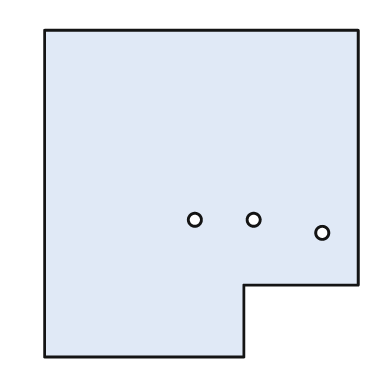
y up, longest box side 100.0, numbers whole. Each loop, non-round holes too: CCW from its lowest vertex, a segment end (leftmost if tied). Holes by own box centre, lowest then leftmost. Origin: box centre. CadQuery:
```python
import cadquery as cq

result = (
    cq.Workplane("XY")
    .moveTo(-48.0, -50.0)
    .lineTo(13.0, -50.0)
    .lineTo(13.0, -28.0)
    .lineTo(48.0, -28.0)
    .lineTo(48.0, 50.0)
    .lineTo(-48.0, 50.0)
    .close()
    .moveTo(37.0, -12.0)
    .circle(2.0)
    .moveTo(-2.0, -8.0)
    .circle(2.0)
    .moveTo(16.0, -8.0)
    .circle(2.0)
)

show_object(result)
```